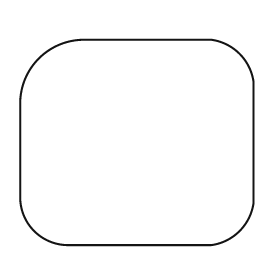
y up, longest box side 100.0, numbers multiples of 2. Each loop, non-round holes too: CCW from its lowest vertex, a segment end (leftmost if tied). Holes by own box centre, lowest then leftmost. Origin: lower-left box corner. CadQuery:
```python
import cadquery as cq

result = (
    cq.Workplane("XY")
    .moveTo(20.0, 0.0)
    .lineTo(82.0, 0.0)
    .threePointArc((94.0, 6.0), (100.0, 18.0))
    .lineTo(100.0, 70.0)
    .threePointArc((94.0, 82.0), (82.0, 88.0))
    .lineTo(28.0, 88.0)
    .threePointArc((8.0, 80.0), (0.0, 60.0))
    .lineTo(0.0, 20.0)
    .threePointArc((6.0, 6.0), (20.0, 0.0))
    .close()
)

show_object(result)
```